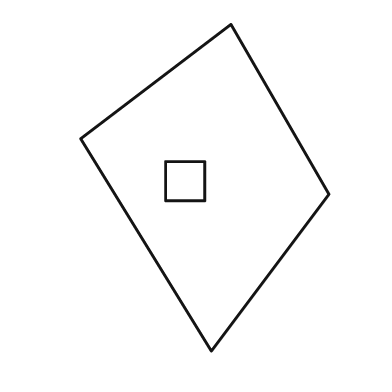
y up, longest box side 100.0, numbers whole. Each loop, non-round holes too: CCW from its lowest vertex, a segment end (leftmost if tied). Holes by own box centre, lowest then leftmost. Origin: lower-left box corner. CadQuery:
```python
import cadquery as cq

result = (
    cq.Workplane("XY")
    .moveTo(40.0, 0.0)
    .lineTo(76.0, 48.0)
    .lineTo(46.0, 100.0)
    .lineTo(0.0, 65.0)
    .close()
    .moveTo(26.0, 46.0)
    .lineTo(38.0, 46.0)
    .lineTo(38.0, 58.0)
    .lineTo(26.0, 58.0)
    .close()
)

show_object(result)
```